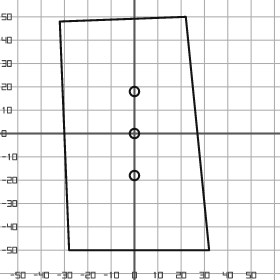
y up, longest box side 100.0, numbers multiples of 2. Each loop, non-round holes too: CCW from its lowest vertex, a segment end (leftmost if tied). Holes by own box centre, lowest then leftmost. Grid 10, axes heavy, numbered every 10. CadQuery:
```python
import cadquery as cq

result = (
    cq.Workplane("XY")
    .moveTo(-28.0, -50.0)
    .lineTo(32.0, -50.0)
    .lineTo(22.0, 50.0)
    .lineTo(-32.0, 48.0)
    .close()
    .moveTo(0.0, -18.0)
    .circle(2.0)
    .moveTo(0.0, 0.0)
    .circle(2.0)
    .moveTo(0.0, 18.0)
    .circle(2.0)
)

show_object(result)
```